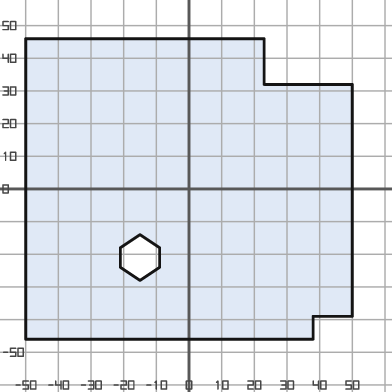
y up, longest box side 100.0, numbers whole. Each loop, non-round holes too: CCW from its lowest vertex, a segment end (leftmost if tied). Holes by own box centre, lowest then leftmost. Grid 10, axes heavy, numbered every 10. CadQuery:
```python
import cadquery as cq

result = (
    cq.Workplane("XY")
    .moveTo(-50.0, -46.0)
    .lineTo(38.0, -46.0)
    .lineTo(38.0, -39.0)
    .lineTo(50.0, -39.0)
    .lineTo(50.0, 32.0)
    .lineTo(23.0, 32.0)
    .lineTo(23.0, 46.0)
    .lineTo(-50.0, 46.0)
    .close()
    .moveTo(-15.0, -28.0)
    .lineTo(-9.0, -24.0)
    .lineTo(-9.0, -18.0)
    .lineTo(-15.0, -14.0)
    .lineTo(-21.0, -18.0)
    .lineTo(-21.0, -24.0)
    .close()
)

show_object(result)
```